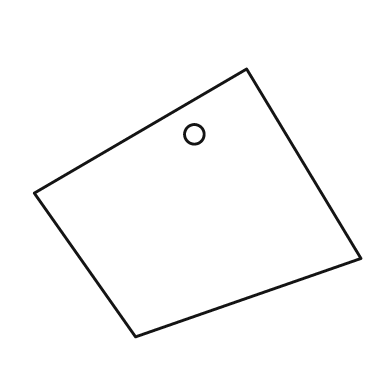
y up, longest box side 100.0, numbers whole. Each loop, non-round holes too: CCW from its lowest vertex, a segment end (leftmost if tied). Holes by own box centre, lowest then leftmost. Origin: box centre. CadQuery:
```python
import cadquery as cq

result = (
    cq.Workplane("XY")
    .moveTo(-19.0, -41.0)
    .lineTo(50.0, -17.0)
    .lineTo(15.0, 41.0)
    .lineTo(-50.0, 3.0)
    .close()
    .moveTo(-1.0, 21.0)
    .circle(3.0)
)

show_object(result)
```